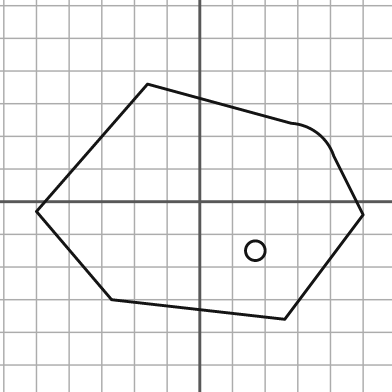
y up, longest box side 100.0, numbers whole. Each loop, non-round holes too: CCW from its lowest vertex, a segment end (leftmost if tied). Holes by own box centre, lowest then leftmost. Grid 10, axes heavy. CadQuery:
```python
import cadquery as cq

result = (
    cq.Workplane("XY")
    .moveTo(26.0, -36.0)
    .lineTo(50.0, -4.0)
    .lineTo(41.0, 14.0)
    .threePointArc((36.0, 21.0), (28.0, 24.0))
    .lineTo(-16.0, 36.0)
    .lineTo(-50.0, -3.0)
    .lineTo(-27.0, -30.0)
    .close()
    .moveTo(17.0, -15.0)
    .circle(3.0)
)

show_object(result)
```